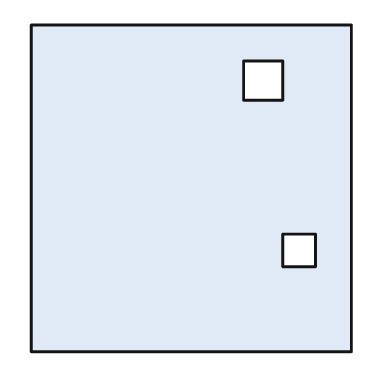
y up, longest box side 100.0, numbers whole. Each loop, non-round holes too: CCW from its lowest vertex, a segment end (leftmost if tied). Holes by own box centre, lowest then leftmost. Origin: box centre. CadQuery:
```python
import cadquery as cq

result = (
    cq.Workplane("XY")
    .moveTo(-49.0, -50.0)
    .lineTo(49.0, -50.0)
    .lineTo(49.0, 50.0)
    .lineTo(-49.0, 50.0)
    .close()
    .moveTo(28.0, -24.0)
    .lineTo(38.0, -24.0)
    .lineTo(38.0, -14.0)
    .lineTo(28.0, -14.0)
    .close()
    .moveTo(16.0, 27.0)
    .lineTo(28.0, 27.0)
    .lineTo(28.0, 39.0)
    .lineTo(16.0, 39.0)
    .close()
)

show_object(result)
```